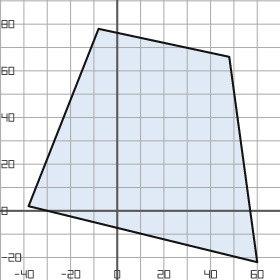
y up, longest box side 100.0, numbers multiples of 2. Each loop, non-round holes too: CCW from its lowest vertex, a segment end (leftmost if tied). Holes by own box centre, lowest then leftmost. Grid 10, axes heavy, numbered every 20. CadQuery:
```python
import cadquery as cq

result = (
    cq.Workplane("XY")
    .moveTo(60.0, -22.0)
    .lineTo(48.0, 66.0)
    .lineTo(-8.0, 78.0)
    .lineTo(-38.0, 2.0)
    .close()
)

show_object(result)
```